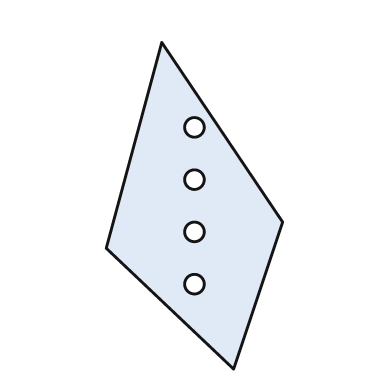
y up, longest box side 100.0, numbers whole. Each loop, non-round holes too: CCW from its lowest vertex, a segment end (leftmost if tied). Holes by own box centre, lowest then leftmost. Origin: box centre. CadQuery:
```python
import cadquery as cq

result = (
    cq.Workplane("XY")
    .moveTo(12.0, -50.0)
    .lineTo(27.0, -5.0)
    .lineTo(-10.0, 50.0)
    .lineTo(-27.0, -13.0)
    .close()
    .moveTo(0.0, -24.0)
    .circle(3.0)
    .moveTo(0.0, -8.0)
    .circle(3.0)
    .moveTo(0.0, 8.0)
    .circle(3.0)
    .moveTo(0.0, 24.0)
    .circle(3.0)
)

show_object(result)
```